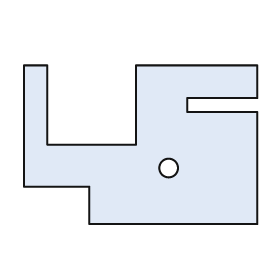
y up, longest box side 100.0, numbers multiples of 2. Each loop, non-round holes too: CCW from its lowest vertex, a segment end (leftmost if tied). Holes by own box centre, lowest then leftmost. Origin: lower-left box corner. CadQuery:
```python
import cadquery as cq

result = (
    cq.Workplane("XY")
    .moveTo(28.0, 0.0)
    .lineTo(100.0, 0.0)
    .lineTo(100.0, 48.0)
    .lineTo(70.0, 48.0)
    .lineTo(70.0, 54.0)
    .lineTo(100.0, 54.0)
    .lineTo(100.0, 68.0)
    .lineTo(48.0, 68.0)
    .lineTo(48.0, 34.0)
    .lineTo(10.0, 34.0)
    .lineTo(10.0, 68.0)
    .lineTo(0.0, 68.0)
    .lineTo(0.0, 16.0)
    .lineTo(28.0, 16.0)
    .close()
    .moveTo(62.0, 24.0)
    .circle(4.0)
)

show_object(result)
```